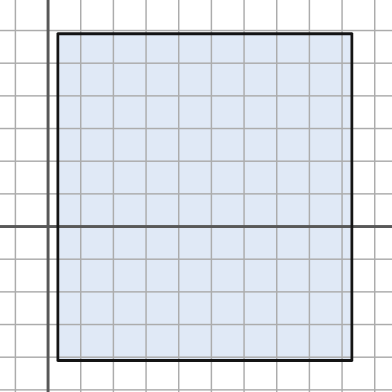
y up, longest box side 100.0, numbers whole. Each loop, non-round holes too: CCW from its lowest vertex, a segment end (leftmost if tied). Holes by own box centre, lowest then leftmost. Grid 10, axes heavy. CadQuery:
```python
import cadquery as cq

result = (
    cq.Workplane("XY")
    .moveTo(3.0, -41.0)
    .lineTo(93.0, -41.0)
    .lineTo(93.0, 59.0)
    .lineTo(3.0, 59.0)
    .close()
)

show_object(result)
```